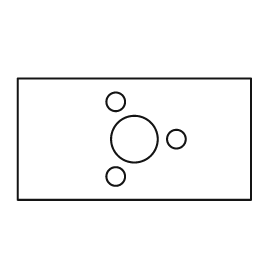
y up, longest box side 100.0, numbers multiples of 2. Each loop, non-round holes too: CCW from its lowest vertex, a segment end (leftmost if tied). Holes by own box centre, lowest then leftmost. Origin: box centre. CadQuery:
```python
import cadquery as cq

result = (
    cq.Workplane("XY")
    .moveTo(-50.0, -26.0)
    .lineTo(50.0, -26.0)
    .lineTo(50.0, 26.0)
    .lineTo(-50.0, 26.0)
    .close()
    .moveTo(-8.0, -16.0)
    .circle(4.0)
    .moveTo(0.0, 0.0)
    .circle(10.0)
    .moveTo(18.0, 0.0)
    .circle(4.0)
    .moveTo(-8.0, 16.0)
    .circle(4.0)
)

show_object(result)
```